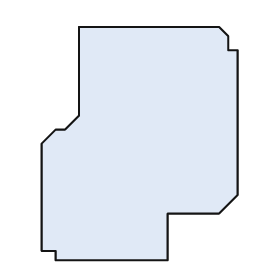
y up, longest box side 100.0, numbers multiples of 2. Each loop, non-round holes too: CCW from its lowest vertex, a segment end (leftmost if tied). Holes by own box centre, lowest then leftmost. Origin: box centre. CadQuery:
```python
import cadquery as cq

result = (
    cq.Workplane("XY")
    .moveTo(-36.0, -50.0)
    .lineTo(12.0, -50.0)
    .lineTo(12.0, -30.0)
    .lineTo(34.0, -30.0)
    .lineTo(42.0, -22.0)
    .lineTo(42.0, 40.0)
    .lineTo(38.0, 40.0)
    .lineTo(38.0, 46.0)
    .lineTo(34.0, 50.0)
    .lineTo(-26.0, 50.0)
    .lineTo(-26.0, 12.0)
    .lineTo(-32.0, 6.0)
    .lineTo(-36.0, 6.0)
    .lineTo(-42.0, 0.0)
    .lineTo(-42.0, -46.0)
    .lineTo(-36.0, -46.0)
    .close()
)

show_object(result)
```